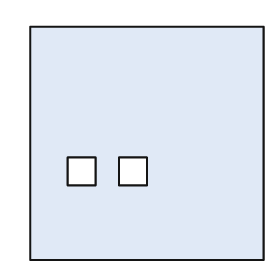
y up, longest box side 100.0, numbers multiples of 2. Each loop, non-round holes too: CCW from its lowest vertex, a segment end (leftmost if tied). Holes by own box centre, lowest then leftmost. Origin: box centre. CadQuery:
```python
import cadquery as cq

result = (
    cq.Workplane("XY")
    .moveTo(-50.0, -50.0)
    .lineTo(50.0, -50.0)
    .lineTo(50.0, 50.0)
    .lineTo(-50.0, 50.0)
    .close()
    .moveTo(-34.0, -18.0)
    .lineTo(-22.0, -18.0)
    .lineTo(-22.0, -6.0)
    .lineTo(-34.0, -6.0)
    .close()
    .moveTo(-12.0, -18.0)
    .lineTo(0.0, -18.0)
    .lineTo(0.0, -6.0)
    .lineTo(-12.0, -6.0)
    .close()
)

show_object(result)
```